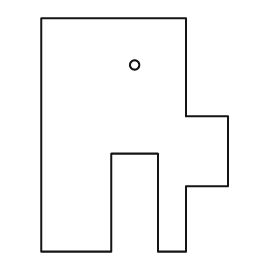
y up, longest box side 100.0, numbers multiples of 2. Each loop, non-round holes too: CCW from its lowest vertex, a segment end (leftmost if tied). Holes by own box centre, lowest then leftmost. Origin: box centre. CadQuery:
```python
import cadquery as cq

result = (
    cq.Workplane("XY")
    .moveTo(-40.0, -50.0)
    .lineTo(-10.0, -50.0)
    .lineTo(-10.0, -8.0)
    .lineTo(10.0, -8.0)
    .lineTo(10.0, -50.0)
    .lineTo(22.0, -50.0)
    .lineTo(22.0, -22.0)
    .lineTo(40.0, -22.0)
    .lineTo(40.0, 8.0)
    .lineTo(22.0, 8.0)
    .lineTo(22.0, 50.0)
    .lineTo(-40.0, 50.0)
    .close()
    .moveTo(0.0, 30.0)
    .circle(2.0)
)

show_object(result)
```